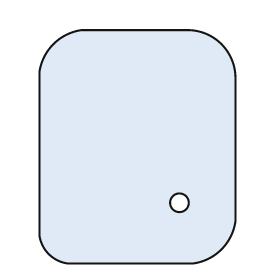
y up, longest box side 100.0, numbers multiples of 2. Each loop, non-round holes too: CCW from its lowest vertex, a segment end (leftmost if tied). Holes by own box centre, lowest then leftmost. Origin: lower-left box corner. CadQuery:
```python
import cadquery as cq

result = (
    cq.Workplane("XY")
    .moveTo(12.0, 0.0)
    .lineTo(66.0, 0.0)
    .threePointArc((78.0, 6.0), (84.0, 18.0))
    .lineTo(84.0, 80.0)
    .threePointArc((78.0, 94.0), (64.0, 100.0))
    .lineTo(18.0, 100.0)
    .threePointArc((6.0, 94.0), (0.0, 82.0))
    .lineTo(0.0, 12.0)
    .threePointArc((4.0, 4.0), (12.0, 0.0))
    .close()
    .moveTo(60.0, 26.0)
    .circle(4.0)
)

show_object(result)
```